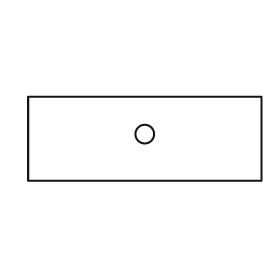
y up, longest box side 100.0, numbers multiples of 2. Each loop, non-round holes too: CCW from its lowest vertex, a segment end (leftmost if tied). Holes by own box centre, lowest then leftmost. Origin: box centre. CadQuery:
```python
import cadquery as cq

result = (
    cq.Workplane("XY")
    .moveTo(-50.0, -18.0)
    .lineTo(50.0, -18.0)
    .lineTo(50.0, 18.0)
    .lineTo(-50.0, 18.0)
    .close()
    .moveTo(0.0, 2.0)
    .circle(4.0)
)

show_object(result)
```